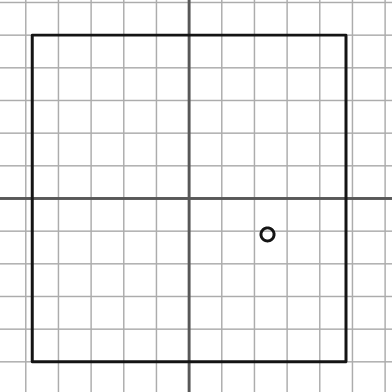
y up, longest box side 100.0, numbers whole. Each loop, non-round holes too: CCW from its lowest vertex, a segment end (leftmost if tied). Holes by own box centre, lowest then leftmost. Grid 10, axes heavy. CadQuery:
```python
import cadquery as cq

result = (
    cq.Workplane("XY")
    .moveTo(-48.0, -50.0)
    .lineTo(48.0, -50.0)
    .lineTo(48.0, 50.0)
    .lineTo(-48.0, 50.0)
    .close()
    .moveTo(24.0, -11.0)
    .circle(2.0)
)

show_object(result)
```